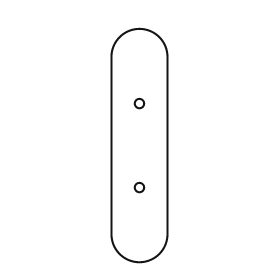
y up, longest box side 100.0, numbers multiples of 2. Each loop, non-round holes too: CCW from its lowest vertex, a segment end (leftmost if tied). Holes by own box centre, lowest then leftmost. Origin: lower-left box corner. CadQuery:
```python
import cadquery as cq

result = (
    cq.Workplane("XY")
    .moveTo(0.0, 12.0)
    .threePointArc((12.0, 0.0), (24.0, 12.0))
    .lineTo(24.0, 88.0)
    .threePointArc((12.0, 100.0), (0.0, 88.0))
    .close()
    .moveTo(12.0, 32.0)
    .circle(2.0)
    .moveTo(12.0, 68.0)
    .circle(2.0)
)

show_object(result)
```